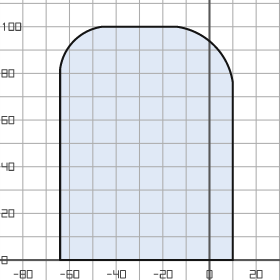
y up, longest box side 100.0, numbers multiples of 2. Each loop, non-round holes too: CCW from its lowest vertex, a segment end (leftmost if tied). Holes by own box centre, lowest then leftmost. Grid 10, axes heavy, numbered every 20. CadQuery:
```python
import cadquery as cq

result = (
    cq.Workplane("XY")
    .moveTo(-64.0, 0.0)
    .lineTo(10.0, 0.0)
    .lineTo(10.0, 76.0)
    .threePointArc((2.0, 92.0), (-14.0, 100.0))
    .lineTo(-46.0, 100.0)
    .threePointArc((-58.0, 94.0), (-64.0, 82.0))
    .close()
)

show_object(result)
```